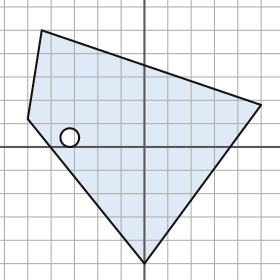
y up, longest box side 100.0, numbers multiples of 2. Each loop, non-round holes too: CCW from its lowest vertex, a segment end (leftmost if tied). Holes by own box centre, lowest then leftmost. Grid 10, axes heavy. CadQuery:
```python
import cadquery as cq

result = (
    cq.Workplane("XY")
    .moveTo(0.0, -50.0)
    .lineTo(50.0, 18.0)
    .lineTo(-44.0, 50.0)
    .lineTo(-50.0, 12.0)
    .close()
    .moveTo(-32.0, 4.0)
    .circle(4.0)
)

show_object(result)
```